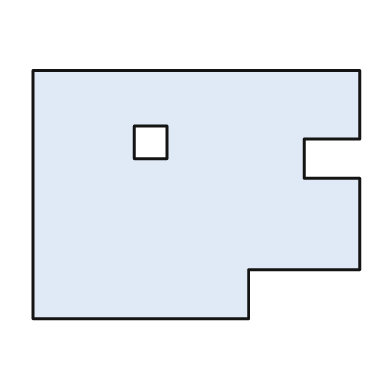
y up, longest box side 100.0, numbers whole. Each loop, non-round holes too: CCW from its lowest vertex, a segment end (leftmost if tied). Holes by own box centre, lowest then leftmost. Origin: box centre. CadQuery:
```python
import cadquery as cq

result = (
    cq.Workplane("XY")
    .moveTo(-50.0, -38.0)
    .lineTo(16.0, -38.0)
    .lineTo(16.0, -23.0)
    .lineTo(50.0, -23.0)
    .lineTo(50.0, 5.0)
    .lineTo(33.0, 5.0)
    .lineTo(33.0, 17.0)
    .lineTo(50.0, 17.0)
    .lineTo(50.0, 38.0)
    .lineTo(-50.0, 38.0)
    .close()
    .moveTo(-19.0, 11.0)
    .lineTo(-9.0, 11.0)
    .lineTo(-9.0, 21.0)
    .lineTo(-19.0, 21.0)
    .close()
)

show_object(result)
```